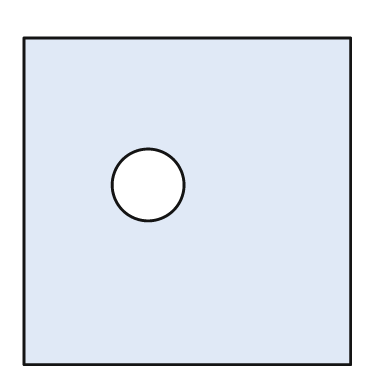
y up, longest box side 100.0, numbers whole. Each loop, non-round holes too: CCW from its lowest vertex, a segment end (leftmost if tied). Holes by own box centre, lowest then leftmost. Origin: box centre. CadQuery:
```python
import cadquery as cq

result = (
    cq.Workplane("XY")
    .moveTo(-50.0, -50.0)
    .lineTo(50.0, -50.0)
    .lineTo(50.0, 50.0)
    .lineTo(-50.0, 50.0)
    .close()
    .moveTo(-12.0, 5.0)
    .circle(11.0)
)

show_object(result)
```